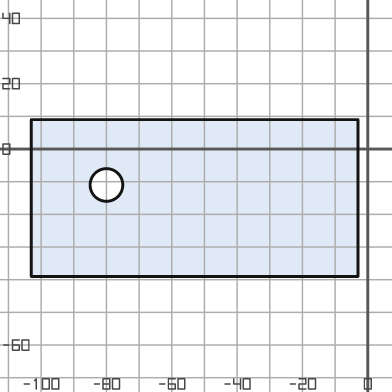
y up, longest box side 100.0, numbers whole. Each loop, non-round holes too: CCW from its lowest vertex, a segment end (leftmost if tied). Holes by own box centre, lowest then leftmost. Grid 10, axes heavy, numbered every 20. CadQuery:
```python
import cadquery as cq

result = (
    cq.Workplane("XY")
    .moveTo(-103.0, -39.0)
    .lineTo(-3.0, -39.0)
    .lineTo(-3.0, 9.0)
    .lineTo(-103.0, 9.0)
    .close()
    .moveTo(-80.0, -11.0)
    .circle(5.0)
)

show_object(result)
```